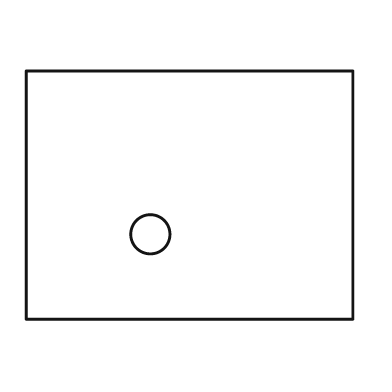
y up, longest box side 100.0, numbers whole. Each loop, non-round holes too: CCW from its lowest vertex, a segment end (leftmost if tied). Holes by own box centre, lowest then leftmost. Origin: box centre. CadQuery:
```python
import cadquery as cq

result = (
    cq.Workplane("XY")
    .moveTo(-50.0, -38.0)
    .lineTo(50.0, -38.0)
    .lineTo(50.0, 38.0)
    .lineTo(-50.0, 38.0)
    .close()
    .moveTo(-12.0, -12.0)
    .circle(6.0)
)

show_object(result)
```